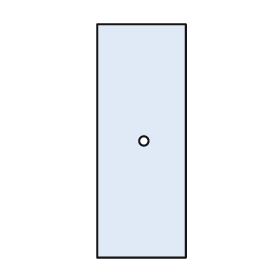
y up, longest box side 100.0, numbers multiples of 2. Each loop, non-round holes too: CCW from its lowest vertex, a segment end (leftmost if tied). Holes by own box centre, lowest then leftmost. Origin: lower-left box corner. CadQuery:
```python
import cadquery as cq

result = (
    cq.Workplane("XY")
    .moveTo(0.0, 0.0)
    .lineTo(38.0, 0.0)
    .lineTo(38.0, 100.0)
    .lineTo(0.0, 100.0)
    .close()
    .moveTo(20.0, 50.0)
    .circle(2.0)
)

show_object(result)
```